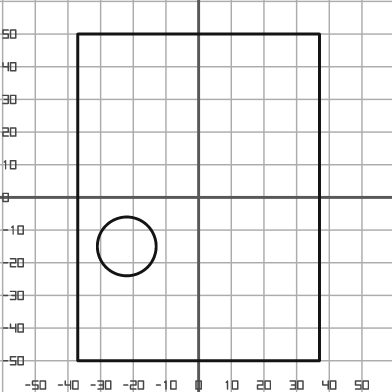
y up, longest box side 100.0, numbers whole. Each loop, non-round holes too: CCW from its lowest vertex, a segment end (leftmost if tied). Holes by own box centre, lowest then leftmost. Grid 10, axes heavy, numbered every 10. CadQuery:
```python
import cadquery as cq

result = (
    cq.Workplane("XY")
    .moveTo(-37.0, -50.0)
    .lineTo(37.0, -50.0)
    .lineTo(37.0, 50.0)
    .lineTo(-37.0, 50.0)
    .close()
    .moveTo(-22.0, -15.0)
    .circle(9.0)
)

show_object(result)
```